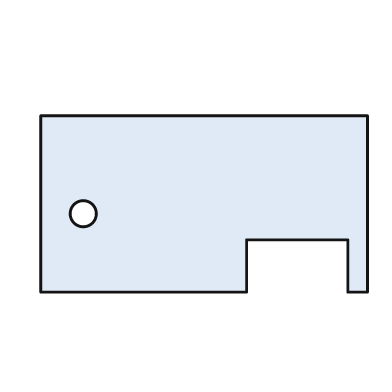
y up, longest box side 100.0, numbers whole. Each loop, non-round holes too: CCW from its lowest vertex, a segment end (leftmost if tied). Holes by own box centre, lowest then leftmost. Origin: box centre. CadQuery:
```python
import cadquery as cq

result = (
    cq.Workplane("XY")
    .moveTo(-50.0, -27.0)
    .lineTo(13.0, -27.0)
    .lineTo(13.0, -11.0)
    .lineTo(44.0, -11.0)
    .lineTo(44.0, -27.0)
    .lineTo(50.0, -27.0)
    .lineTo(50.0, 27.0)
    .lineTo(-50.0, 27.0)
    .close()
    .moveTo(-37.0, -3.0)
    .circle(4.0)
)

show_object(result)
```